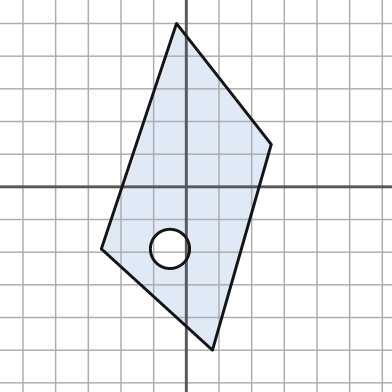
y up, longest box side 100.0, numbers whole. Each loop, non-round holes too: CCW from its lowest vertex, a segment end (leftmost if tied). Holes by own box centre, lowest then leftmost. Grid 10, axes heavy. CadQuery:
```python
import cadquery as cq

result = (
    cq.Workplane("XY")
    .moveTo(8.0, -50.0)
    .lineTo(26.0, 13.0)
    .lineTo(-3.0, 50.0)
    .lineTo(-26.0, -19.0)
    .close()
    .moveTo(-5.0, -19.0)
    .circle(6.0)
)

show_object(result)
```